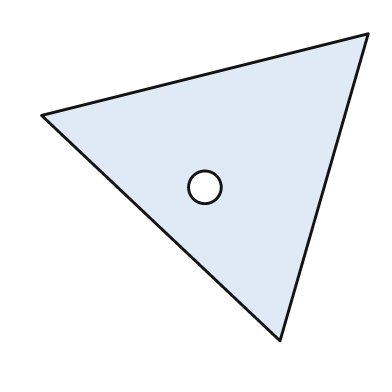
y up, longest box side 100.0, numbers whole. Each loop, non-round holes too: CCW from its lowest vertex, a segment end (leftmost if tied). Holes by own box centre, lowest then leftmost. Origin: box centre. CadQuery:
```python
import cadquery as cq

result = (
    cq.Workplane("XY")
    .moveTo(23.0, -47.0)
    .lineTo(50.0, 47.0)
    .lineTo(-50.0, 22.0)
    .close()
    .moveTo(0.0, 0.0)
    .circle(5.0)
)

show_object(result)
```